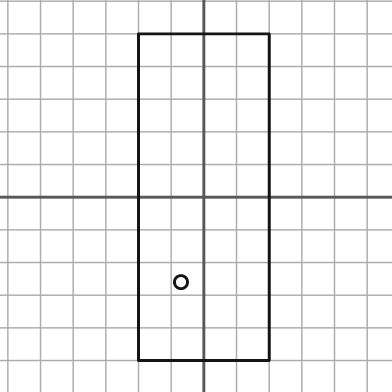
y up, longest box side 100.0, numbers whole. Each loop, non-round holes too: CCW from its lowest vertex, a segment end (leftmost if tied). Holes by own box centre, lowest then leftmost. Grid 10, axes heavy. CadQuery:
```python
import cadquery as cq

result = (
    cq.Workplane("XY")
    .moveTo(-20.0, -50.0)
    .lineTo(20.0, -50.0)
    .lineTo(20.0, 50.0)
    .lineTo(-20.0, 50.0)
    .close()
    .moveTo(-7.0, -26.0)
    .circle(2.0)
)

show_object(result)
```